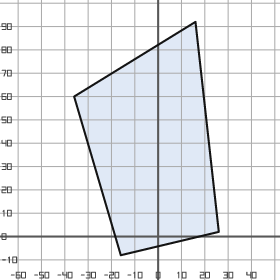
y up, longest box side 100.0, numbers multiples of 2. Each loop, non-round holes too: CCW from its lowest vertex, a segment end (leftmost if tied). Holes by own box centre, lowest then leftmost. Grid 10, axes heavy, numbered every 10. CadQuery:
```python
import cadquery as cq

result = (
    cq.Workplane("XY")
    .moveTo(-16.0, -8.0)
    .lineTo(26.0, 2.0)
    .lineTo(16.0, 92.0)
    .lineTo(-36.0, 60.0)
    .close()
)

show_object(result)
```